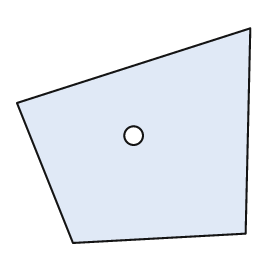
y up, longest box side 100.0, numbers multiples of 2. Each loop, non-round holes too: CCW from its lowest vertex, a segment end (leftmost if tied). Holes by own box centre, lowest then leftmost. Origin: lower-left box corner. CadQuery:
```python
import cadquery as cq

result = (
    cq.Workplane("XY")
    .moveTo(24.0, 0.0)
    .lineTo(98.0, 4.0)
    .lineTo(100.0, 92.0)
    .lineTo(0.0, 60.0)
    .close()
    .moveTo(50.0, 46.0)
    .circle(4.0)
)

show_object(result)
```